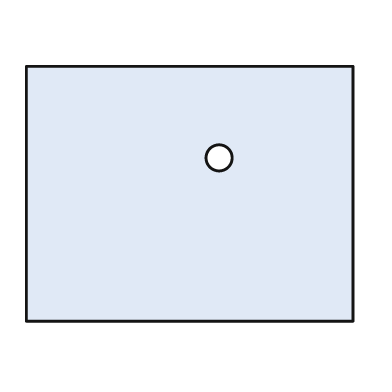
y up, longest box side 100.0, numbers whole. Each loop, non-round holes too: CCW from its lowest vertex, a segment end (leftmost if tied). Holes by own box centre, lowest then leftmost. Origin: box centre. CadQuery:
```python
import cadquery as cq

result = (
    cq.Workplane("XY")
    .moveTo(-50.0, -39.0)
    .lineTo(50.0, -39.0)
    .lineTo(50.0, 39.0)
    .lineTo(-50.0, 39.0)
    .close()
    .moveTo(9.0, 11.0)
    .circle(4.0)
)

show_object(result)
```